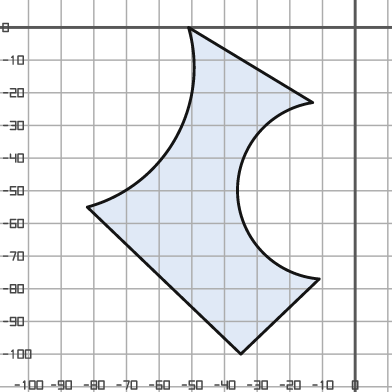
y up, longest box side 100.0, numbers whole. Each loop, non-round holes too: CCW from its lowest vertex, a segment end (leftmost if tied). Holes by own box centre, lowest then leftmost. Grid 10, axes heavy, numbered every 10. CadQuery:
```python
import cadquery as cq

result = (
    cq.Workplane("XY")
    .moveTo(-35.0, -100.0)
    .lineTo(-11.0, -77.0)
    .threePointArc((-36.0, -51.0), (-13.0, -23.0))
    .lineTo(-51.0, 0.0)
    .threePointArc((-55.0, -34.0), (-82.0, -55.0))
    .close()
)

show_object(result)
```